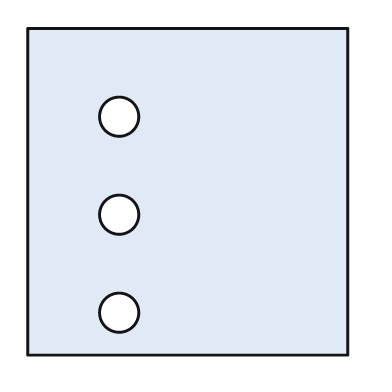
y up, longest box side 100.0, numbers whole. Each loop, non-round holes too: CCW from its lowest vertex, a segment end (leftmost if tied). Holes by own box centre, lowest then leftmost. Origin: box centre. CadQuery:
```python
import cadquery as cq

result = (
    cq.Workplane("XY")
    .moveTo(-49.0, -50.0)
    .lineTo(49.0, -50.0)
    .lineTo(49.0, 50.0)
    .lineTo(-49.0, 50.0)
    .close()
    .moveTo(-21.0, -37.0)
    .circle(6.0)
    .moveTo(-21.0, -7.0)
    .circle(6.0)
    .moveTo(-21.0, 23.0)
    .circle(6.0)
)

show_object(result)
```